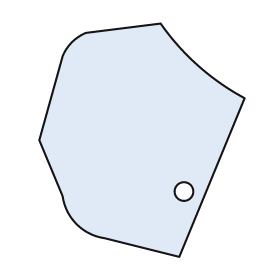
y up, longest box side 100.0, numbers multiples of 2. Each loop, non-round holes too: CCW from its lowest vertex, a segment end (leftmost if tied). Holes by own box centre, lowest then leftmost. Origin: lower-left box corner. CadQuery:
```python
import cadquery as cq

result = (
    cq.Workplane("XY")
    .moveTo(60.0, 0.0)
    .lineTo(88.0, 68.0)
    .threePointArc((68.0, 82.0), (52.0, 100.0))
    .lineTo(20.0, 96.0)
    .threePointArc((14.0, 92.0), (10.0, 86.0))
    .lineTo(0.0, 50.0)
    .lineTo(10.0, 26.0)
    .threePointArc((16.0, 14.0), (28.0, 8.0))
    .close()
    .moveTo(62.0, 28.0)
    .circle(4.0)
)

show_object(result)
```